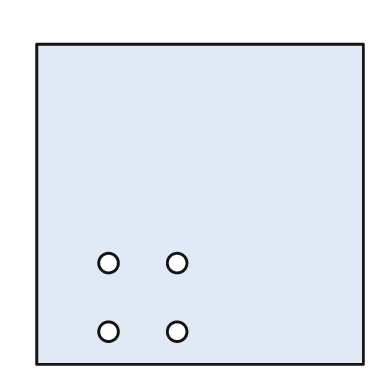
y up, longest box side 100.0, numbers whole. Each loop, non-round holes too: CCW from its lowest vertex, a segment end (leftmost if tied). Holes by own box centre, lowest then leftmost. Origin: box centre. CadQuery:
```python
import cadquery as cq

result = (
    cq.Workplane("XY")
    .moveTo(-50.0, -49.0)
    .lineTo(50.0, -49.0)
    .lineTo(50.0, 49.0)
    .lineTo(-50.0, 49.0)
    .close()
    .moveTo(-28.0, -39.0)
    .circle(3.0)
    .moveTo(-7.0, -39.0)
    .circle(3.0)
    .moveTo(-28.0, -18.0)
    .circle(3.0)
    .moveTo(-7.0, -18.0)
    .circle(3.0)
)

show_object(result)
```